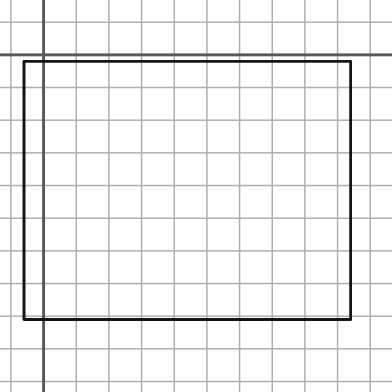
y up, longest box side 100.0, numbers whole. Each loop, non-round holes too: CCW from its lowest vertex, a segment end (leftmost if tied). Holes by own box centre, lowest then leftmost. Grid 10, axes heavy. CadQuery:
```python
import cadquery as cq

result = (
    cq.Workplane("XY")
    .moveTo(-6.0, -81.0)
    .lineTo(94.0, -81.0)
    .lineTo(94.0, -2.0)
    .lineTo(-6.0, -2.0)
    .close()
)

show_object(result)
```